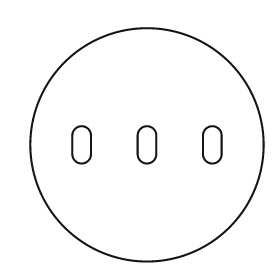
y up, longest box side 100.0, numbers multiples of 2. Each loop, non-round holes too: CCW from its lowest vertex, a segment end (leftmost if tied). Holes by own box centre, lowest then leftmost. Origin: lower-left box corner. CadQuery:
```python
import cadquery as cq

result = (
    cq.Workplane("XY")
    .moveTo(50.0, 50.0)
    .circle(50.0)
    .moveTo(18.0, 46.0)
    .threePointArc((22.0, 42.0), (26.0, 46.0))
    .lineTo(26.0, 54.0)
    .threePointArc((22.0, 58.0), (18.0, 54.0))
    .close()
    .moveTo(46.0, 46.0)
    .threePointArc((50.0, 42.0), (54.0, 46.0))
    .lineTo(54.0, 54.0)
    .threePointArc((50.0, 58.0), (46.0, 54.0))
    .close()
    .moveTo(74.0, 46.0)
    .threePointArc((78.0, 42.0), (82.0, 46.0))
    .lineTo(82.0, 54.0)
    .threePointArc((78.0, 58.0), (74.0, 54.0))
    .close()
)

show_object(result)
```